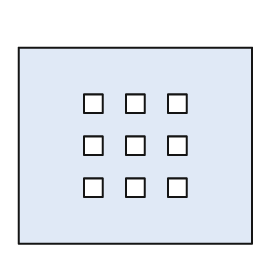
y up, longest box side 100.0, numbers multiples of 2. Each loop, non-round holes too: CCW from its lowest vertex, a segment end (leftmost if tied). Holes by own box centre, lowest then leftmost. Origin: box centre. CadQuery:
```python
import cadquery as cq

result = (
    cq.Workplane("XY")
    .moveTo(-50.0, -42.0)
    .lineTo(50.0, -42.0)
    .lineTo(50.0, 42.0)
    .lineTo(-50.0, 42.0)
    .close()
    .moveTo(-22.0, -22.0)
    .lineTo(-14.0, -22.0)
    .lineTo(-14.0, -14.0)
    .lineTo(-22.0, -14.0)
    .close()
    .moveTo(-4.0, -22.0)
    .lineTo(4.0, -22.0)
    .lineTo(4.0, -14.0)
    .lineTo(-4.0, -14.0)
    .close()
    .moveTo(14.0, -22.0)
    .lineTo(22.0, -22.0)
    .lineTo(22.0, -14.0)
    .lineTo(14.0, -14.0)
    .close()
    .moveTo(-22.0, -4.0)
    .lineTo(-14.0, -4.0)
    .lineTo(-14.0, 4.0)
    .lineTo(-22.0, 4.0)
    .close()
    .moveTo(-4.0, -4.0)
    .lineTo(4.0, -4.0)
    .lineTo(4.0, 4.0)
    .lineTo(-4.0, 4.0)
    .close()
    .moveTo(14.0, -4.0)
    .lineTo(22.0, -4.0)
    .lineTo(22.0, 4.0)
    .lineTo(14.0, 4.0)
    .close()
    .moveTo(-22.0, 14.0)
    .lineTo(-14.0, 14.0)
    .lineTo(-14.0, 22.0)
    .lineTo(-22.0, 22.0)
    .close()
    .moveTo(-4.0, 14.0)
    .lineTo(4.0, 14.0)
    .lineTo(4.0, 22.0)
    .lineTo(-4.0, 22.0)
    .close()
    .moveTo(14.0, 14.0)
    .lineTo(22.0, 14.0)
    .lineTo(22.0, 22.0)
    .lineTo(14.0, 22.0)
    .close()
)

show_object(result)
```